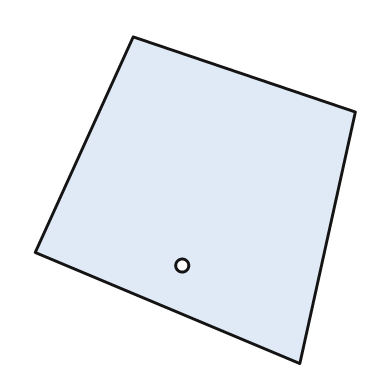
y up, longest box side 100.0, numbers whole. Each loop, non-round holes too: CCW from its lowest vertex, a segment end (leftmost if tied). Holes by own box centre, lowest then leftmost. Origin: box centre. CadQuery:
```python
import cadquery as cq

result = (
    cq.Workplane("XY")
    .moveTo(32.0, -50.0)
    .lineTo(49.0, 27.0)
    .lineTo(-19.0, 50.0)
    .lineTo(-49.0, -16.0)
    .close()
    .moveTo(-4.0, -20.0)
    .circle(2.0)
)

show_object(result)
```